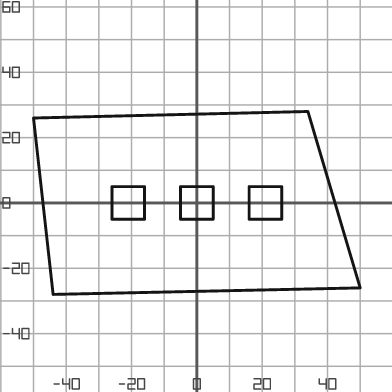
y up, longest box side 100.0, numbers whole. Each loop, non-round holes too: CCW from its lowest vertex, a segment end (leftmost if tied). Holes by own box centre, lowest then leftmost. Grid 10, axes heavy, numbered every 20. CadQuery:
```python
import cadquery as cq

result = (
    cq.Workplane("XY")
    .moveTo(-44.0, -28.0)
    .lineTo(50.0, -26.0)
    .lineTo(34.0, 28.0)
    .lineTo(-50.0, 26.0)
    .close()
    .moveTo(-26.0, -5.0)
    .lineTo(-16.0, -5.0)
    .lineTo(-16.0, 5.0)
    .lineTo(-26.0, 5.0)
    .close()
    .moveTo(-5.0, -5.0)
    .lineTo(5.0, -5.0)
    .lineTo(5.0, 5.0)
    .lineTo(-5.0, 5.0)
    .close()
    .moveTo(16.0, -5.0)
    .lineTo(26.0, -5.0)
    .lineTo(26.0, 5.0)
    .lineTo(16.0, 5.0)
    .close()
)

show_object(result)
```